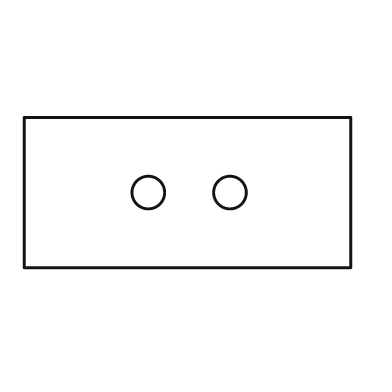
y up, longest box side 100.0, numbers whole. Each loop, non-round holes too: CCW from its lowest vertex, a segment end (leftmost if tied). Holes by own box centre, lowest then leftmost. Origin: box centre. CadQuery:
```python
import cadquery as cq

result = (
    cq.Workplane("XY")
    .moveTo(-50.0, -23.0)
    .lineTo(50.0, -23.0)
    .lineTo(50.0, 23.0)
    .lineTo(-50.0, 23.0)
    .close()
    .moveTo(-12.0, 0.0)
    .circle(5.0)
    .moveTo(13.0, 0.0)
    .circle(5.0)
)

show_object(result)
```